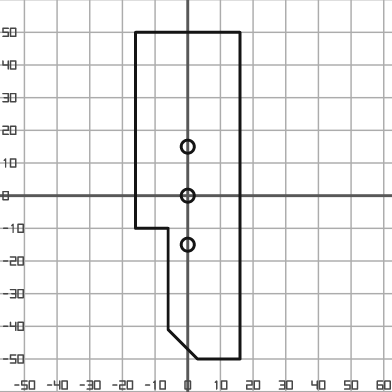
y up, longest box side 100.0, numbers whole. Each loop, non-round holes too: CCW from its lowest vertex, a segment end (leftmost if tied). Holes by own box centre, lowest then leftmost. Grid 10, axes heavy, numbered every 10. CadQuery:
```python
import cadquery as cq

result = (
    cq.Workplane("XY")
    .moveTo(3.0, -50.0)
    .lineTo(16.0, -50.0)
    .lineTo(16.0, 50.0)
    .lineTo(-16.0, 50.0)
    .lineTo(-16.0, -10.0)
    .lineTo(-6.0, -10.0)
    .lineTo(-6.0, -41.0)
    .close()
    .moveTo(0.0, -15.0)
    .circle(2.0)
    .moveTo(0.0, 0.0)
    .circle(2.0)
    .moveTo(0.0, 15.0)
    .circle(2.0)
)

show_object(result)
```